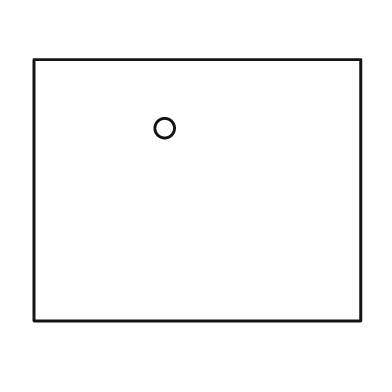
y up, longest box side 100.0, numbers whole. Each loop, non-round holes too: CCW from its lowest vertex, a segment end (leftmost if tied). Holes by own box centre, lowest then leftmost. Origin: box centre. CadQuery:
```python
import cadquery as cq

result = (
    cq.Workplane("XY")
    .moveTo(-50.0, -40.0)
    .lineTo(50.0, -40.0)
    .lineTo(50.0, 40.0)
    .lineTo(-50.0, 40.0)
    .close()
    .moveTo(-10.0, 19.0)
    .circle(3.0)
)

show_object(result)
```